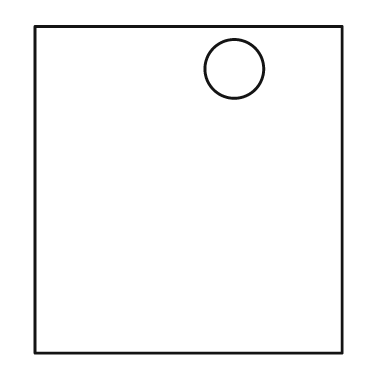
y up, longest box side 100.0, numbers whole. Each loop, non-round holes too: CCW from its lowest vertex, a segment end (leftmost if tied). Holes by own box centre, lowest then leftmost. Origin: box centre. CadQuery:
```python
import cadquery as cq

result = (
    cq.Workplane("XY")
    .moveTo(-47.0, -50.0)
    .lineTo(47.0, -50.0)
    .lineTo(47.0, 50.0)
    .lineTo(-47.0, 50.0)
    .close()
    .moveTo(14.0, 37.0)
    .circle(9.0)
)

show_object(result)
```